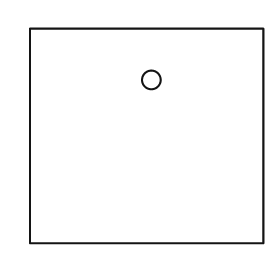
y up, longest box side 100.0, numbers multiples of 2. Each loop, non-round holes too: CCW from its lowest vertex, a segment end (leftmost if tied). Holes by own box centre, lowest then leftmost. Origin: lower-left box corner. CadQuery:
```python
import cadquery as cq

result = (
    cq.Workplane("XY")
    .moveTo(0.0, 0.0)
    .lineTo(100.0, 0.0)
    .lineTo(100.0, 92.0)
    .lineTo(0.0, 92.0)
    .close()
    .moveTo(52.0, 70.0)
    .circle(4.0)
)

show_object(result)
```